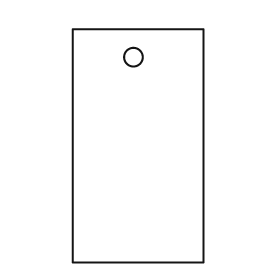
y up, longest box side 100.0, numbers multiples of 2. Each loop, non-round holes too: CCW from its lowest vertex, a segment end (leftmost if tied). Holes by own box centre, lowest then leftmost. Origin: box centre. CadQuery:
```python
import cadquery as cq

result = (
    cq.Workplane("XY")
    .moveTo(-28.0, -50.0)
    .lineTo(28.0, -50.0)
    .lineTo(28.0, 50.0)
    .lineTo(-28.0, 50.0)
    .close()
    .moveTo(-2.0, 38.0)
    .circle(4.0)
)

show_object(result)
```